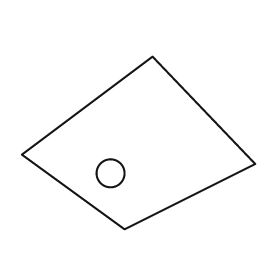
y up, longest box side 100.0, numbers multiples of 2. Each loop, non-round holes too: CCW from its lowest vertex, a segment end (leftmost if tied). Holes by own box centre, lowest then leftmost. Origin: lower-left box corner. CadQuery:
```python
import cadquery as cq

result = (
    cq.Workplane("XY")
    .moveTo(44.0, 0.0)
    .lineTo(100.0, 28.0)
    .lineTo(56.0, 74.0)
    .lineTo(0.0, 32.0)
    .close()
    .moveTo(38.0, 24.0)
    .circle(6.0)
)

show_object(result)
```